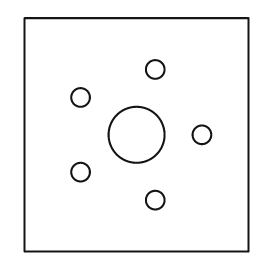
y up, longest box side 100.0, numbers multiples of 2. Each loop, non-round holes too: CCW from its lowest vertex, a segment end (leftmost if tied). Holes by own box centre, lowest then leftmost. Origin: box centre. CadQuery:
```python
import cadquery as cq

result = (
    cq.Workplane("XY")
    .moveTo(-48.0, -50.0)
    .lineTo(48.0, -50.0)
    .lineTo(48.0, 50.0)
    .lineTo(-48.0, 50.0)
    .close()
    .moveTo(8.0, -28.0)
    .circle(4.0)
    .moveTo(-24.0, -16.0)
    .circle(4.0)
    .moveTo(0.0, 0.0)
    .circle(12.0)
    .moveTo(28.0, 0.0)
    .circle(4.0)
    .moveTo(-24.0, 16.0)
    .circle(4.0)
    .moveTo(8.0, 28.0)
    .circle(4.0)
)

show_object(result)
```